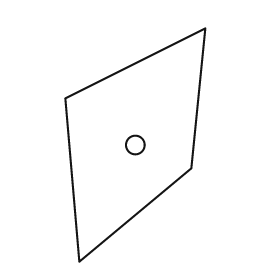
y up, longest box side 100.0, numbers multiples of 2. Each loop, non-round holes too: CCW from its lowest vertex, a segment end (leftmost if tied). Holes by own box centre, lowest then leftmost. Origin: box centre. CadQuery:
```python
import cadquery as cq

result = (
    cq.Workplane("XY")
    .moveTo(-24.0, -50.0)
    .lineTo(24.0, -10.0)
    .lineTo(30.0, 50.0)
    .lineTo(-30.0, 20.0)
    .close()
    .moveTo(0.0, 0.0)
    .circle(4.0)
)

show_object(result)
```